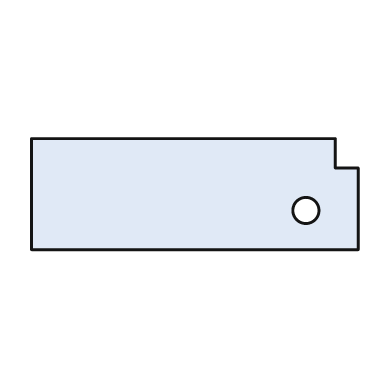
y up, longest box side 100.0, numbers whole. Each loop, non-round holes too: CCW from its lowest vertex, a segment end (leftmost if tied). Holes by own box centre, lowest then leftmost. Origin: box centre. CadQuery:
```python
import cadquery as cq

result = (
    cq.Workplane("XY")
    .moveTo(-50.0, -17.0)
    .lineTo(50.0, -17.0)
    .lineTo(50.0, 8.0)
    .lineTo(43.0, 8.0)
    .lineTo(43.0, 17.0)
    .lineTo(-50.0, 17.0)
    .close()
    .moveTo(34.0, -5.0)
    .circle(4.0)
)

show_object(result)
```